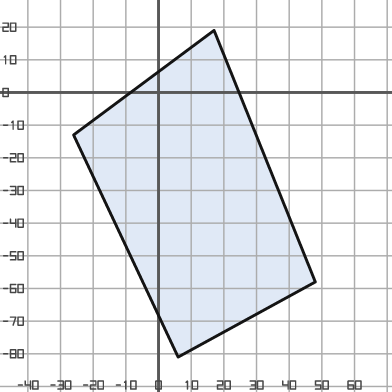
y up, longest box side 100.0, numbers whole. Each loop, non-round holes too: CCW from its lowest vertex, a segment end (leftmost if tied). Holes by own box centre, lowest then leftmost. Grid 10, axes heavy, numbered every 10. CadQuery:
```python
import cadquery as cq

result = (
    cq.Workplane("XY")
    .moveTo(6.0, -81.0)
    .lineTo(48.0, -58.0)
    .lineTo(17.0, 19.0)
    .lineTo(-26.0, -13.0)
    .close()
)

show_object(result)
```